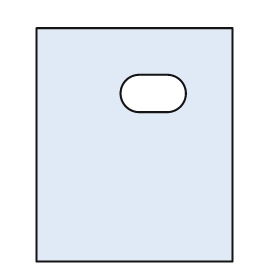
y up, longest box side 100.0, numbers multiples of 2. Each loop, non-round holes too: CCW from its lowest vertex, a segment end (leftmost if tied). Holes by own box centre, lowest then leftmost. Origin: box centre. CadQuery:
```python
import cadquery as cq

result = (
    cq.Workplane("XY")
    .moveTo(-42.0, -50.0)
    .lineTo(42.0, -50.0)
    .lineTo(42.0, 50.0)
    .lineTo(-42.0, 50.0)
    .close()
    .moveTo(2.0, 14.0)
    .lineTo(14.0, 14.0)
    .threePointArc((22.0, 22.0), (14.0, 30.0))
    .lineTo(2.0, 30.0)
    .threePointArc((-6.0, 22.0), (2.0, 14.0))
    .close()
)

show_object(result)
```